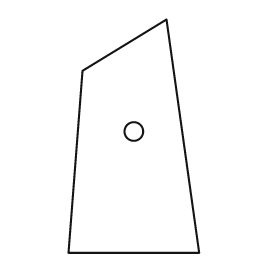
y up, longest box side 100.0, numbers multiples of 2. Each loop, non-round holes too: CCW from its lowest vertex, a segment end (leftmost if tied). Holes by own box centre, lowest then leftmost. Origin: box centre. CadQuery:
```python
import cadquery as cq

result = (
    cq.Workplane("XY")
    .moveTo(-28.0, -50.0)
    .lineTo(28.0, -50.0)
    .lineTo(14.0, 50.0)
    .lineTo(-22.0, 28.0)
    .close()
    .moveTo(0.0, 2.0)
    .circle(4.0)
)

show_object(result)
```